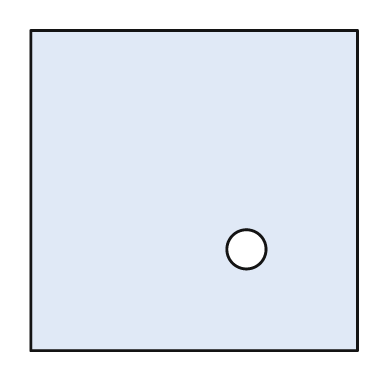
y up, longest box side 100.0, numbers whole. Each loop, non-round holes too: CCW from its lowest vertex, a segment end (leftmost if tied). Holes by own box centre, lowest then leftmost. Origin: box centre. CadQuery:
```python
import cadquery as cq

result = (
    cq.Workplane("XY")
    .moveTo(-50.0, -49.0)
    .lineTo(50.0, -49.0)
    .lineTo(50.0, 49.0)
    .lineTo(-50.0, 49.0)
    .close()
    .moveTo(16.0, -18.0)
    .circle(6.0)
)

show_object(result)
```